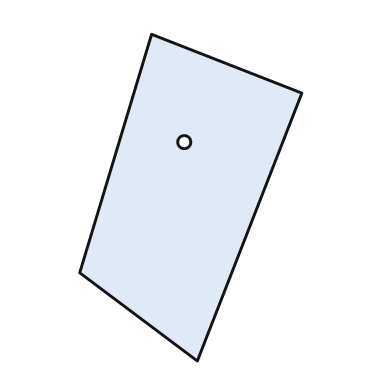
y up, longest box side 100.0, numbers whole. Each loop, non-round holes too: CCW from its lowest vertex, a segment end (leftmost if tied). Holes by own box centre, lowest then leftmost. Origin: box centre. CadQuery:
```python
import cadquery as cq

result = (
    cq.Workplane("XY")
    .moveTo(2.0, -50.0)
    .lineTo(34.0, 32.0)
    .lineTo(-12.0, 50.0)
    .lineTo(-34.0, -23.0)
    .close()
    .moveTo(-2.0, 17.0)
    .circle(2.0)
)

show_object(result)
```